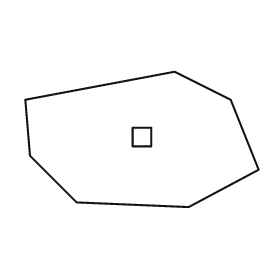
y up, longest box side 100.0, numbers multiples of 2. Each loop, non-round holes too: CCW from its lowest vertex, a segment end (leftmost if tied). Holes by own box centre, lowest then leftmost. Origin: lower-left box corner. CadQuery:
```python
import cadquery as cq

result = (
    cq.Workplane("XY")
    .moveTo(70.0, 0.0)
    .lineTo(100.0, 16.0)
    .lineTo(88.0, 46.0)
    .lineTo(64.0, 58.0)
    .lineTo(0.0, 46.0)
    .lineTo(2.0, 22.0)
    .lineTo(22.0, 2.0)
    .close()
    .moveTo(46.0, 26.0)
    .lineTo(54.0, 26.0)
    .lineTo(54.0, 34.0)
    .lineTo(46.0, 34.0)
    .close()
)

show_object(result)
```